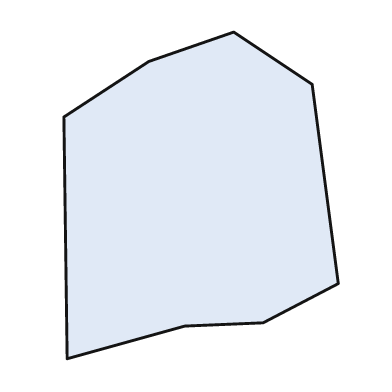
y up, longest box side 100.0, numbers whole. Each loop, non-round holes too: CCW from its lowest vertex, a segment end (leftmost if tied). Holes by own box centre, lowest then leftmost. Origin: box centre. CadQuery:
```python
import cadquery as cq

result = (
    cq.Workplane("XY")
    .moveTo(-41.0, -50.0)
    .lineTo(-5.0, -40.0)
    .lineTo(19.0, -39.0)
    .lineTo(42.0, -27.0)
    .lineTo(34.0, 34.0)
    .lineTo(10.0, 50.0)
    .lineTo(-16.0, 41.0)
    .lineTo(-42.0, 24.0)
    .close()
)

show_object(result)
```